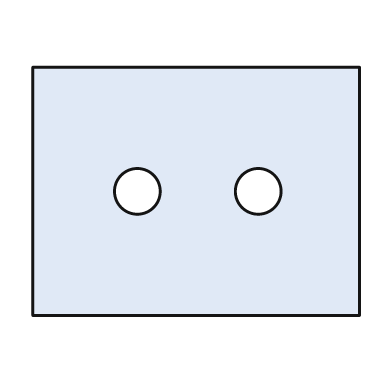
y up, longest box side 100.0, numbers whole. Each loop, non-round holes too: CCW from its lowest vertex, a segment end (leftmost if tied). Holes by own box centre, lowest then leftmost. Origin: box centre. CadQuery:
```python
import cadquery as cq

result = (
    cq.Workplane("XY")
    .moveTo(-50.0, -38.0)
    .lineTo(50.0, -38.0)
    .lineTo(50.0, 38.0)
    .lineTo(-50.0, 38.0)
    .close()
    .moveTo(-18.0, 0.0)
    .circle(7.0)
    .moveTo(19.0, 0.0)
    .circle(7.0)
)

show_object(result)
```